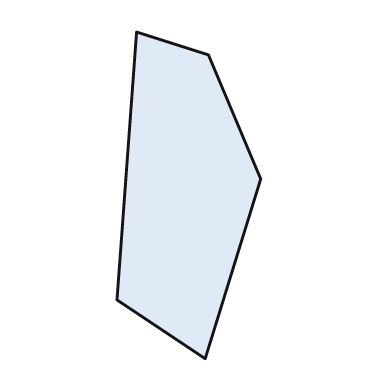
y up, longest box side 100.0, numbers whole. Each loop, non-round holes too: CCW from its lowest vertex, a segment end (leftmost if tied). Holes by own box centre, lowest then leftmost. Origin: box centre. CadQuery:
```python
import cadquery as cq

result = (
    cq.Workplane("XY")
    .moveTo(5.0, -50.0)
    .lineTo(22.0, 5.0)
    .lineTo(6.0, 43.0)
    .lineTo(-16.0, 50.0)
    .lineTo(-22.0, -32.0)
    .close()
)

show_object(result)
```